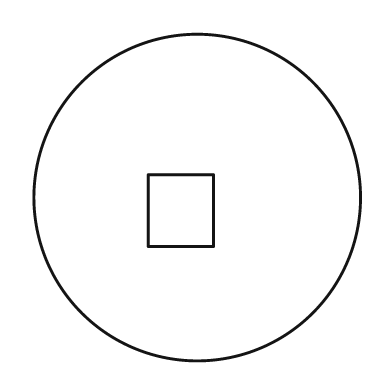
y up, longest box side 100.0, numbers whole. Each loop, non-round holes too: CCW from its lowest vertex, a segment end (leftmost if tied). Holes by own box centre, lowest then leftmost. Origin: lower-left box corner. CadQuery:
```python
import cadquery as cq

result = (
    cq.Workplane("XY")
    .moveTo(50.0, 50.0)
    .circle(50.0)
    .moveTo(35.0, 35.0)
    .lineTo(55.0, 35.0)
    .lineTo(55.0, 57.0)
    .lineTo(35.0, 57.0)
    .close()
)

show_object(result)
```